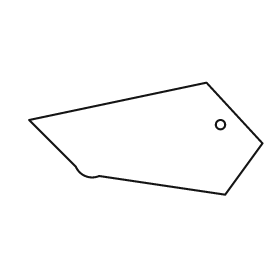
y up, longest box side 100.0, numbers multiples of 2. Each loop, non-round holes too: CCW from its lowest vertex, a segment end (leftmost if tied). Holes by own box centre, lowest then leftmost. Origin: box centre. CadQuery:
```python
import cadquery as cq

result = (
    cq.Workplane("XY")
    .moveTo(34.0, -24.0)
    .lineTo(50.0, -2.0)
    .lineTo(26.0, 24.0)
    .lineTo(-50.0, 8.0)
    .lineTo(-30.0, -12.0)
    .threePointArc((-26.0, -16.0), (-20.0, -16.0))
    .close()
    .moveTo(32.0, 6.0)
    .circle(2.0)
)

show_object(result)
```